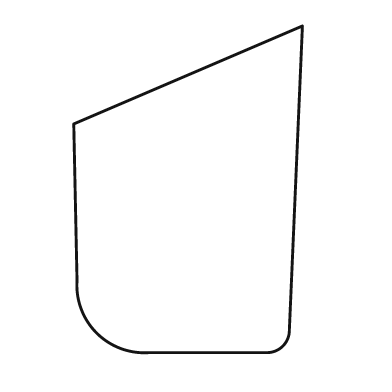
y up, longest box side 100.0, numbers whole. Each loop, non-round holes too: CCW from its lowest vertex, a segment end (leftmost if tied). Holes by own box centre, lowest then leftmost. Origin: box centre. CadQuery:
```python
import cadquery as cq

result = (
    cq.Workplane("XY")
    .moveTo(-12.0, -50.0)
    .lineTo(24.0, -50.0)
    .threePointArc((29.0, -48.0), (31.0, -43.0))
    .lineTo(35.0, 50.0)
    .lineTo(-35.0, 20.0)
    .lineTo(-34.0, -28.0)
    .threePointArc((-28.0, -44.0), (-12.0, -50.0))
    .close()
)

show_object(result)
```